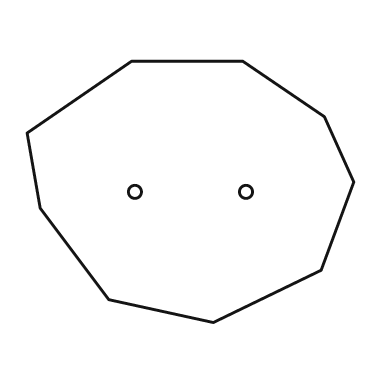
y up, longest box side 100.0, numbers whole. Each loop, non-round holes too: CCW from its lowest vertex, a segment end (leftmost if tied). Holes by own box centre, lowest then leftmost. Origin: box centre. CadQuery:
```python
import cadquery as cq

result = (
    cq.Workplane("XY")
    .moveTo(7.0, -40.0)
    .lineTo(40.0, -24.0)
    .lineTo(50.0, 3.0)
    .lineTo(41.0, 23.0)
    .lineTo(16.0, 40.0)
    .lineTo(-18.0, 40.0)
    .lineTo(-50.0, 18.0)
    .lineTo(-46.0, -5.0)
    .lineTo(-25.0, -33.0)
    .close()
    .moveTo(-17.0, 0.0)
    .circle(2.0)
    .moveTo(17.0, 0.0)
    .circle(2.0)
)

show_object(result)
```